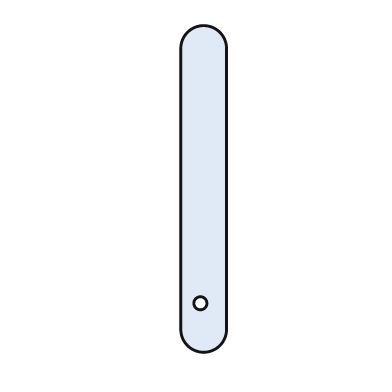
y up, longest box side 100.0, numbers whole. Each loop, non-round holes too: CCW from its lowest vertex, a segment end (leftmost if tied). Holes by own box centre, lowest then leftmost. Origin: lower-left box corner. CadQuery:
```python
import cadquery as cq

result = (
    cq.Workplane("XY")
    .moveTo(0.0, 7.0)
    .threePointArc((7.0, 0.0), (14.0, 7.0))
    .lineTo(14.0, 93.0)
    .threePointArc((7.0, 100.0), (0.0, 93.0))
    .close()
    .moveTo(6.0, 15.0)
    .circle(2.0)
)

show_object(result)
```